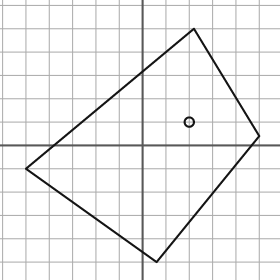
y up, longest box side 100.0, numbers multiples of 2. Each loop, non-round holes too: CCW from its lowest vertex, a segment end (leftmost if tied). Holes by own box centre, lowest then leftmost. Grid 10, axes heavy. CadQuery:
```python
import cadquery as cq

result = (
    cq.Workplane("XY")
    .moveTo(6.0, -50.0)
    .lineTo(50.0, 4.0)
    .lineTo(22.0, 50.0)
    .lineTo(-50.0, -10.0)
    .close()
    .moveTo(20.0, 10.0)
    .circle(2.0)
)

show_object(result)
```